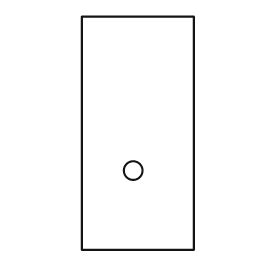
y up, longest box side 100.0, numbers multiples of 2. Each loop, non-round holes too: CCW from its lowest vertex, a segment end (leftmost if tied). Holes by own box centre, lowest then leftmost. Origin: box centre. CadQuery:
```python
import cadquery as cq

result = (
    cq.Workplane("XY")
    .moveTo(-24.0, -50.0)
    .lineTo(24.0, -50.0)
    .lineTo(24.0, 50.0)
    .lineTo(-24.0, 50.0)
    .close()
    .moveTo(-2.0, -16.0)
    .circle(4.0)
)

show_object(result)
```